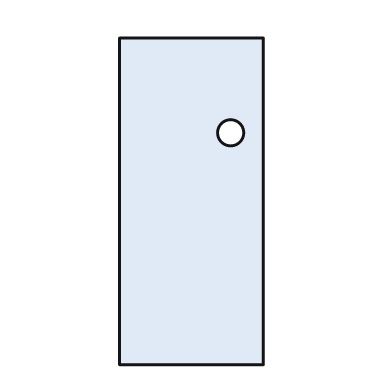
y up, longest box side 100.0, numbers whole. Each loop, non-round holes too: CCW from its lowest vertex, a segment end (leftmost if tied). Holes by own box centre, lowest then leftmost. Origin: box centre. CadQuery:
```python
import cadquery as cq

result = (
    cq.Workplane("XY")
    .moveTo(-22.0, -50.0)
    .lineTo(22.0, -50.0)
    .lineTo(22.0, 50.0)
    .lineTo(-22.0, 50.0)
    .close()
    .moveTo(12.0, 21.0)
    .circle(4.0)
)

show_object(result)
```